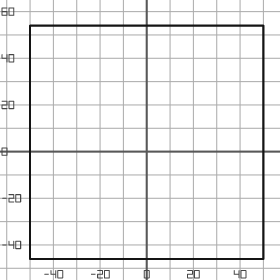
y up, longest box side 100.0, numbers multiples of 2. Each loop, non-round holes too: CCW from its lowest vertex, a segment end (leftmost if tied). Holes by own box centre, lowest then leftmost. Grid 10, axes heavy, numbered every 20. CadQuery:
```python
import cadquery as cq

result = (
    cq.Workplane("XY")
    .moveTo(-50.0, -46.0)
    .lineTo(50.0, -46.0)
    .lineTo(50.0, 54.0)
    .lineTo(-50.0, 54.0)
    .close()
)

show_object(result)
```